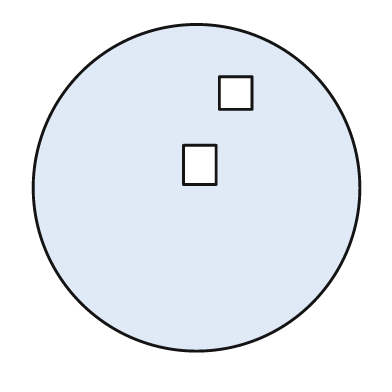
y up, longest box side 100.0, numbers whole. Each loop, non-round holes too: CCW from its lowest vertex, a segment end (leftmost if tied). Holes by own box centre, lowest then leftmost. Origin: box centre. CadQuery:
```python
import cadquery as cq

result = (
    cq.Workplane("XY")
    .moveTo(0.0, 0.0)
    .circle(50.0)
    .moveTo(-4.0, 1.0)
    .lineTo(6.0, 1.0)
    .lineTo(6.0, 13.0)
    .lineTo(-4.0, 13.0)
    .close()
    .moveTo(7.0, 24.0)
    .lineTo(17.0, 24.0)
    .lineTo(17.0, 34.0)
    .lineTo(7.0, 34.0)
    .close()
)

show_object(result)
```